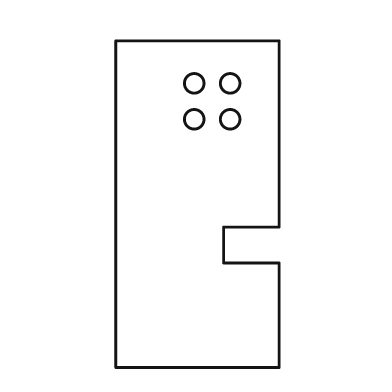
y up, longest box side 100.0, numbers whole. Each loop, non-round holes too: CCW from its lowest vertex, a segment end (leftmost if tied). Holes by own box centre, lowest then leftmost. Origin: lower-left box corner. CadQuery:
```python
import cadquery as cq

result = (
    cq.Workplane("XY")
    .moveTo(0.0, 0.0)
    .lineTo(50.0, 0.0)
    .lineTo(50.0, 32.0)
    .lineTo(33.0, 32.0)
    .lineTo(33.0, 43.0)
    .lineTo(50.0, 43.0)
    .lineTo(50.0, 100.0)
    .lineTo(0.0, 100.0)
    .close()
    .moveTo(24.0, 76.0)
    .circle(3.0)
    .moveTo(35.0, 76.0)
    .circle(3.0)
    .moveTo(24.0, 87.0)
    .circle(3.0)
    .moveTo(35.0, 87.0)
    .circle(3.0)
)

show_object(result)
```